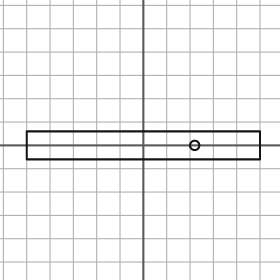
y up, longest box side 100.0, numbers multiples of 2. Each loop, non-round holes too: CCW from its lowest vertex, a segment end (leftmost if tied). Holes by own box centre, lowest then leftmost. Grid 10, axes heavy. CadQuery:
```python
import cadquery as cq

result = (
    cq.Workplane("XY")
    .moveTo(-50.0, -6.0)
    .lineTo(50.0, -6.0)
    .lineTo(50.0, 6.0)
    .lineTo(-50.0, 6.0)
    .close()
    .moveTo(22.0, 0.0)
    .circle(2.0)
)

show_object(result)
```